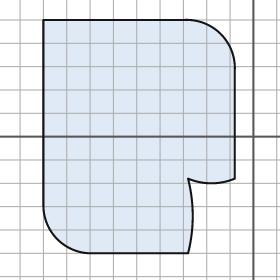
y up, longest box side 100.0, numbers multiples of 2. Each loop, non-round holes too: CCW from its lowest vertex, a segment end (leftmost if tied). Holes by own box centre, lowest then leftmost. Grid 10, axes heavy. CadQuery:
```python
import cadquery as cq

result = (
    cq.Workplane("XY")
    .moveTo(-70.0, -50.0)
    .lineTo(-28.0, -50.0)
    .threePointArc((-26.0, -34.0), (-28.0, -18.0))
    .threePointArc((-18.0, -20.0), (-8.0, -18.0))
    .lineTo(-8.0, 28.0)
    .threePointArc((-14.0, 44.0), (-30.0, 50.0))
    .lineTo(-90.0, 50.0)
    .lineTo(-90.0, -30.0)
    .threePointArc((-84.0, -44.0), (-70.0, -50.0))
    .close()
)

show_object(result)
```